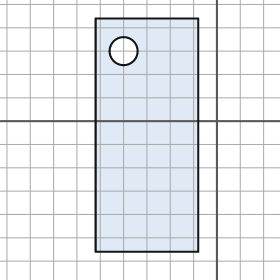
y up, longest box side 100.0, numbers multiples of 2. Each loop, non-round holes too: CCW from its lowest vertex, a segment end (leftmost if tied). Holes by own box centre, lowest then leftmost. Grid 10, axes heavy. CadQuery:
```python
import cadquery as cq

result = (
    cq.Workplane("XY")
    .moveTo(-52.0, -56.0)
    .lineTo(-8.0, -56.0)
    .lineTo(-8.0, 44.0)
    .lineTo(-52.0, 44.0)
    .close()
    .moveTo(-40.0, 30.0)
    .circle(6.0)
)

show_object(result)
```